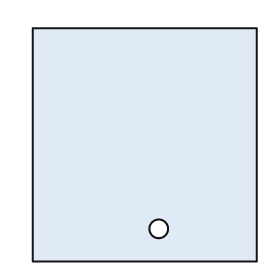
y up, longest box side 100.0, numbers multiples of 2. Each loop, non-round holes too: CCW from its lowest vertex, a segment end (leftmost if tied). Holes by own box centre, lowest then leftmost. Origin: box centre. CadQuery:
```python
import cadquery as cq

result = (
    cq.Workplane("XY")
    .moveTo(-48.0, -50.0)
    .lineTo(48.0, -50.0)
    .lineTo(48.0, 50.0)
    .lineTo(-48.0, 50.0)
    .close()
    .moveTo(6.0, -36.0)
    .circle(4.0)
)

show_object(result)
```